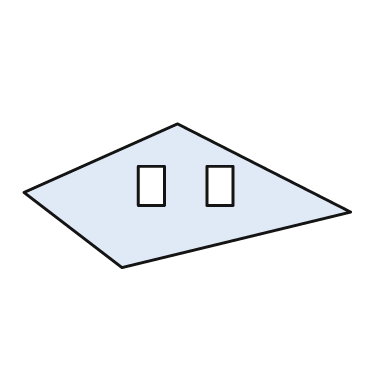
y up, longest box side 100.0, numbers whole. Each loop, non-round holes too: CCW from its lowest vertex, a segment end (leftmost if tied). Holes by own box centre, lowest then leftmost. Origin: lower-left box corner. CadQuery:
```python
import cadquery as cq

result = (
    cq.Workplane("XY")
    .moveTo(30.0, 0.0)
    .lineTo(100.0, 17.0)
    .lineTo(47.0, 44.0)
    .lineTo(0.0, 23.0)
    .close()
    .moveTo(35.0, 19.0)
    .lineTo(43.0, 19.0)
    .lineTo(43.0, 31.0)
    .lineTo(35.0, 31.0)
    .close()
    .moveTo(56.0, 19.0)
    .lineTo(64.0, 19.0)
    .lineTo(64.0, 31.0)
    .lineTo(56.0, 31.0)
    .close()
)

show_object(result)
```